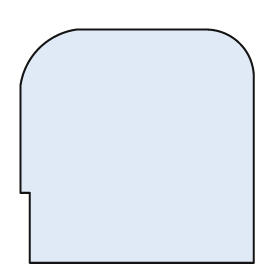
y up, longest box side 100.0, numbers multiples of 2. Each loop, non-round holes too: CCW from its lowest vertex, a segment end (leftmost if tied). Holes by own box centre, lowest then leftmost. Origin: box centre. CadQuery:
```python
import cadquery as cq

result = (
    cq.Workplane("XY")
    .moveTo(-46.0, -50.0)
    .lineTo(50.0, -50.0)
    .lineTo(50.0, 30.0)
    .threePointArc((44.0, 44.0), (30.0, 50.0))
    .lineTo(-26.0, 50.0)
    .threePointArc((-42.0, 42.0), (-50.0, 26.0))
    .lineTo(-50.0, -20.0)
    .lineTo(-46.0, -20.0)
    .close()
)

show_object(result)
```